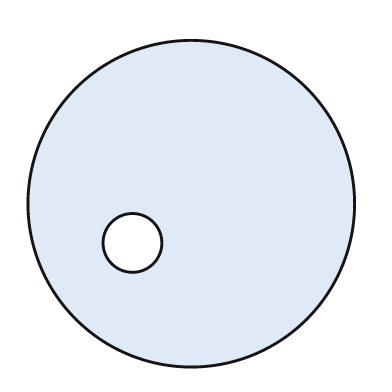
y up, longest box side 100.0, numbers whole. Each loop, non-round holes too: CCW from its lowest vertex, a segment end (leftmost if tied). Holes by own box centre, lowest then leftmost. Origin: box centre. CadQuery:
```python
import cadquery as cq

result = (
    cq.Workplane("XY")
    .moveTo(0.0, 0.0)
    .circle(50.0)
    .moveTo(-18.0, -12.0)
    .circle(9.0)
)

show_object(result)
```